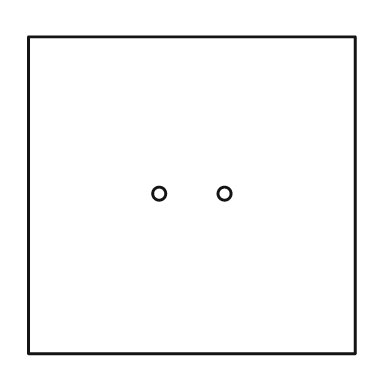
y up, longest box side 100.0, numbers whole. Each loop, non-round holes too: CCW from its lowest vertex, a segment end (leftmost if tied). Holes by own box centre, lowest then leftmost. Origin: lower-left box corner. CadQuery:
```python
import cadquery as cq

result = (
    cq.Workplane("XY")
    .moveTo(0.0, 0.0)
    .lineTo(100.0, 0.0)
    .lineTo(100.0, 97.0)
    .lineTo(0.0, 97.0)
    .close()
    .moveTo(40.0, 49.0)
    .circle(2.0)
    .moveTo(60.0, 49.0)
    .circle(2.0)
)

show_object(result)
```